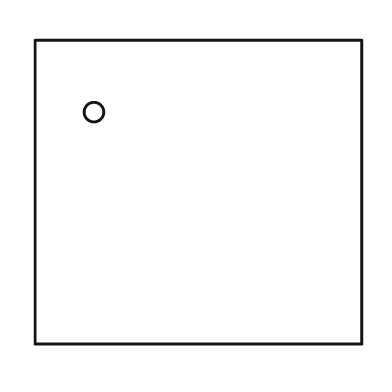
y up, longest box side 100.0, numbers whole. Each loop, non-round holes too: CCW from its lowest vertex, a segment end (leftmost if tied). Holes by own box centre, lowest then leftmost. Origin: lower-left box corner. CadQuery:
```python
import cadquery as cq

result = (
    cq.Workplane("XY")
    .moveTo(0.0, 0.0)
    .lineTo(100.0, 0.0)
    .lineTo(100.0, 93.0)
    .lineTo(0.0, 93.0)
    .close()
    .moveTo(18.0, 71.0)
    .circle(3.0)
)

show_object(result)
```